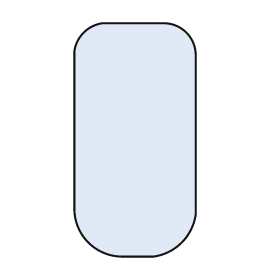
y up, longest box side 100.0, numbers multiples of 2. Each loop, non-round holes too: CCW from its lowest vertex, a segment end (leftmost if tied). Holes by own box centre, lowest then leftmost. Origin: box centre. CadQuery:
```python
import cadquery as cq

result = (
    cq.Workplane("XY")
    .moveTo(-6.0, -50.0)
    .lineTo(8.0, -50.0)
    .threePointArc((20.0, -44.0), (26.0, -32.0))
    .lineTo(26.0, 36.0)
    .threePointArc((22.0, 46.0), (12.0, 50.0))
    .lineTo(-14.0, 50.0)
    .threePointArc((-22.0, 46.0), (-26.0, 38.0))
    .lineTo(-26.0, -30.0)
    .threePointArc((-20.0, -44.0), (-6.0, -50.0))
    .close()
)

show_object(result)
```